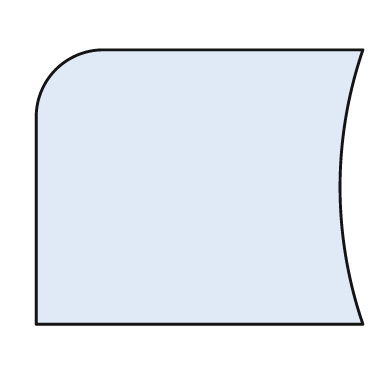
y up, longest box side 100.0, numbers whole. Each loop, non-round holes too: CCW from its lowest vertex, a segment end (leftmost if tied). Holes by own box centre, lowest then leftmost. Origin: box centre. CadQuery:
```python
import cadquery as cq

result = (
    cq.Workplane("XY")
    .moveTo(-50.0, -42.0)
    .lineTo(50.0, -42.0)
    .threePointArc((43.0, 0.0), (50.0, 42.0))
    .lineTo(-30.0, 42.0)
    .threePointArc((-44.0, 36.0), (-50.0, 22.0))
    .close()
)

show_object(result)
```